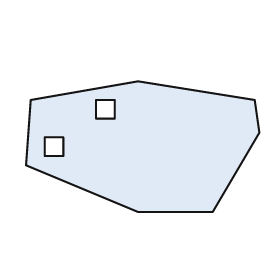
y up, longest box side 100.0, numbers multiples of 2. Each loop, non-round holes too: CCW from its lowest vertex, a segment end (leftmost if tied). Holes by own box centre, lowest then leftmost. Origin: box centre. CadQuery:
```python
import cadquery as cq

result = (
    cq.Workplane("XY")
    .moveTo(-2.0, -28.0)
    .lineTo(30.0, -28.0)
    .lineTo(50.0, 6.0)
    .lineTo(48.0, 20.0)
    .lineTo(-2.0, 28.0)
    .lineTo(-48.0, 20.0)
    .lineTo(-50.0, -8.0)
    .close()
    .moveTo(-42.0, -4.0)
    .lineTo(-34.0, -4.0)
    .lineTo(-34.0, 4.0)
    .lineTo(-42.0, 4.0)
    .close()
    .moveTo(-20.0, 12.0)
    .lineTo(-12.0, 12.0)
    .lineTo(-12.0, 20.0)
    .lineTo(-20.0, 20.0)
    .close()
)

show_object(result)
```